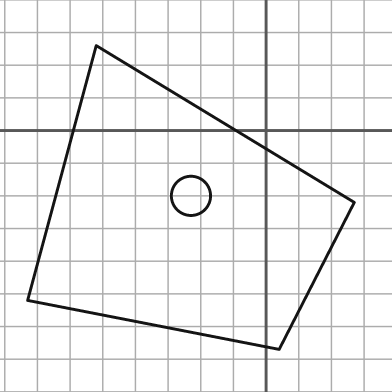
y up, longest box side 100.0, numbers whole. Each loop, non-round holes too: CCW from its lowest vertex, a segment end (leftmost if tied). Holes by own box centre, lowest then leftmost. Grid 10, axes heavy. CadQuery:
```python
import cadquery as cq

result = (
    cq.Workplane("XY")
    .moveTo(4.0, -67.0)
    .lineTo(27.0, -22.0)
    .lineTo(-52.0, 26.0)
    .lineTo(-73.0, -52.0)
    .close()
    .moveTo(-23.0, -20.0)
    .circle(6.0)
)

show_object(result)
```